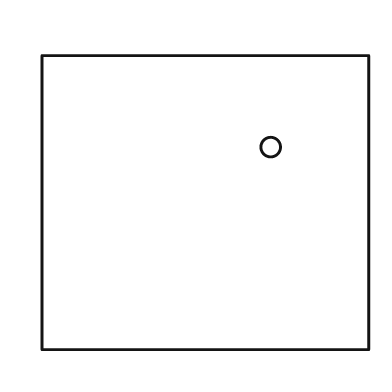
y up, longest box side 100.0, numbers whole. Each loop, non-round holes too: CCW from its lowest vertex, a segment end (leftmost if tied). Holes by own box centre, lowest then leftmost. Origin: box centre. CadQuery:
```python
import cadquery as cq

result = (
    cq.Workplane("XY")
    .moveTo(-50.0, -45.0)
    .lineTo(50.0, -45.0)
    .lineTo(50.0, 45.0)
    .lineTo(-50.0, 45.0)
    .close()
    .moveTo(20.0, 17.0)
    .circle(3.0)
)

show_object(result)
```